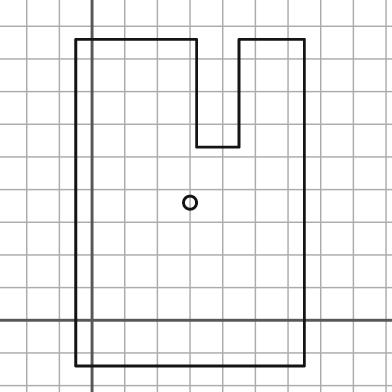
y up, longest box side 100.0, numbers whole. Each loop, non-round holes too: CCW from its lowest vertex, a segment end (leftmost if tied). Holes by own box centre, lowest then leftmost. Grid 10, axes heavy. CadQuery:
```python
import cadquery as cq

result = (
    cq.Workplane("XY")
    .moveTo(-5.0, -14.0)
    .lineTo(65.0, -14.0)
    .lineTo(65.0, 86.0)
    .lineTo(45.0, 86.0)
    .lineTo(45.0, 53.0)
    .lineTo(32.0, 53.0)
    .lineTo(32.0, 86.0)
    .lineTo(-5.0, 86.0)
    .close()
    .moveTo(30.0, 36.0)
    .circle(2.0)
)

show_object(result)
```